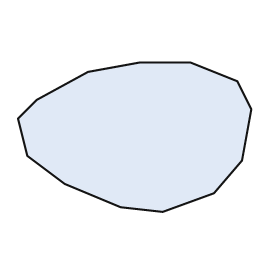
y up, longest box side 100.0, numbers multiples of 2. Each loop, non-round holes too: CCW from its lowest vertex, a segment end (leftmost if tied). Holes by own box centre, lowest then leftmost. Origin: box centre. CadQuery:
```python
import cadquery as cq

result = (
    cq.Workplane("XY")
    .moveTo(12.0, -32.0)
    .lineTo(34.0, -24.0)
    .lineTo(46.0, -10.0)
    .lineTo(50.0, 12.0)
    .lineTo(44.0, 24.0)
    .lineTo(24.0, 32.0)
    .lineTo(2.0, 32.0)
    .lineTo(-20.0, 28.0)
    .lineTo(-42.0, 16.0)
    .lineTo(-50.0, 8.0)
    .lineTo(-46.0, -8.0)
    .lineTo(-30.0, -20.0)
    .lineTo(-6.0, -30.0)
    .close()
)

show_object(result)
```